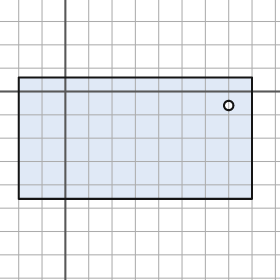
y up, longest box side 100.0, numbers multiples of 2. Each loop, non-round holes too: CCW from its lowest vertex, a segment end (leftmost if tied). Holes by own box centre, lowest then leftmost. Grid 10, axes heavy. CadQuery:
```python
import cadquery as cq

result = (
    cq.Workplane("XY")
    .moveTo(-20.0, -46.0)
    .lineTo(80.0, -46.0)
    .lineTo(80.0, 6.0)
    .lineTo(-20.0, 6.0)
    .close()
    .moveTo(70.0, -6.0)
    .circle(2.0)
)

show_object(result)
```